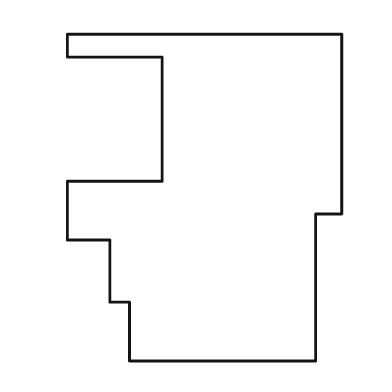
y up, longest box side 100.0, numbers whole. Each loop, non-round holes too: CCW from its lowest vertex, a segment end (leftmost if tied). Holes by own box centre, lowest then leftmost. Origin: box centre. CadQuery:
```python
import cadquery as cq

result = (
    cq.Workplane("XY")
    .moveTo(-23.0, -50.0)
    .lineTo(34.0, -50.0)
    .lineTo(34.0, -5.0)
    .lineTo(42.0, -5.0)
    .lineTo(42.0, 50.0)
    .lineTo(-42.0, 50.0)
    .lineTo(-42.0, 43.0)
    .lineTo(-13.0, 43.0)
    .lineTo(-13.0, 5.0)
    .lineTo(-42.0, 5.0)
    .lineTo(-42.0, -13.0)
    .lineTo(-29.0, -13.0)
    .lineTo(-29.0, -32.0)
    .lineTo(-23.0, -32.0)
    .close()
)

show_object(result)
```